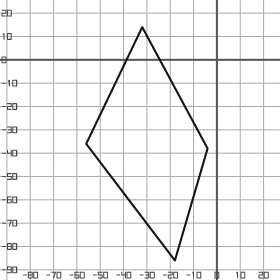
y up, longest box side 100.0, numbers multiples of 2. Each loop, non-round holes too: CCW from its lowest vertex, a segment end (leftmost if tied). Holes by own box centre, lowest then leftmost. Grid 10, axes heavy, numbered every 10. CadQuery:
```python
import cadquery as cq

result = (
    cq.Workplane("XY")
    .moveTo(-18.0, -86.0)
    .lineTo(-4.0, -38.0)
    .lineTo(-32.0, 14.0)
    .lineTo(-56.0, -36.0)
    .close()
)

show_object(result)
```